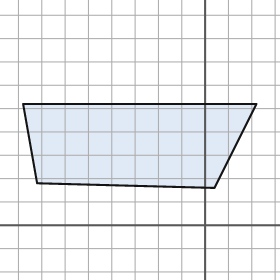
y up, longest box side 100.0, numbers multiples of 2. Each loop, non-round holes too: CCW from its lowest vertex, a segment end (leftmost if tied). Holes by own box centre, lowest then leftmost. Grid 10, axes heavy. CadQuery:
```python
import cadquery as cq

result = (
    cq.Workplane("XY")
    .moveTo(4.0, 16.0)
    .lineTo(22.0, 52.0)
    .lineTo(-78.0, 52.0)
    .lineTo(-72.0, 18.0)
    .close()
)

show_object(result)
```